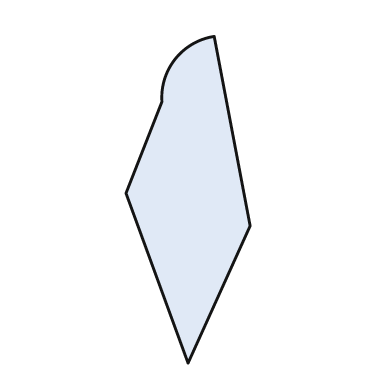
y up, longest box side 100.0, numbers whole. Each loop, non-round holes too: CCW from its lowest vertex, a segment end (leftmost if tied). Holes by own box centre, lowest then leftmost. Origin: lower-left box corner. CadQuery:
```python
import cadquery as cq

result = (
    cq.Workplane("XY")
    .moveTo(19.0, 0.0)
    .lineTo(38.0, 42.0)
    .lineTo(27.0, 100.0)
    .threePointArc((15.0, 93.0), (11.0, 80.0))
    .lineTo(0.0, 52.0)
    .close()
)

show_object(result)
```